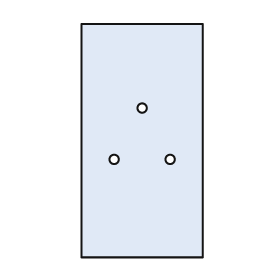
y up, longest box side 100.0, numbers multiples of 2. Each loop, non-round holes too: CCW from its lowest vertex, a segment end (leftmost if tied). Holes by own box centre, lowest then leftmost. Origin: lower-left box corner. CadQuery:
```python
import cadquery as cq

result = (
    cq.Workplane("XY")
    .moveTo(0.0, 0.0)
    .lineTo(52.0, 0.0)
    .lineTo(52.0, 100.0)
    .lineTo(0.0, 100.0)
    .close()
    .moveTo(14.0, 42.0)
    .circle(2.0)
    .moveTo(38.0, 42.0)
    .circle(2.0)
    .moveTo(26.0, 64.0)
    .circle(2.0)
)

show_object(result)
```